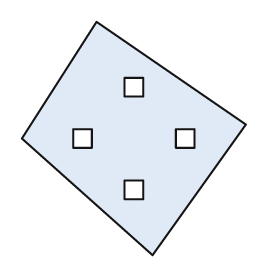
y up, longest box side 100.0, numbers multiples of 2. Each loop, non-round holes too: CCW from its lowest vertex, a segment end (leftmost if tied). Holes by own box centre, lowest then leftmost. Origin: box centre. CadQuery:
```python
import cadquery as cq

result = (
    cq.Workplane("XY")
    .moveTo(8.0, -50.0)
    .lineTo(48.0, 6.0)
    .lineTo(-16.0, 50.0)
    .lineTo(-48.0, 0.0)
    .close()
    .moveTo(-4.0, -26.0)
    .lineTo(4.0, -26.0)
    .lineTo(4.0, -18.0)
    .lineTo(-4.0, -18.0)
    .close()
    .moveTo(-26.0, -4.0)
    .lineTo(-18.0, -4.0)
    .lineTo(-18.0, 4.0)
    .lineTo(-26.0, 4.0)
    .close()
    .moveTo(18.0, -4.0)
    .lineTo(26.0, -4.0)
    .lineTo(26.0, 4.0)
    .lineTo(18.0, 4.0)
    .close()
    .moveTo(-4.0, 18.0)
    .lineTo(4.0, 18.0)
    .lineTo(4.0, 26.0)
    .lineTo(-4.0, 26.0)
    .close()
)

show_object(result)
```